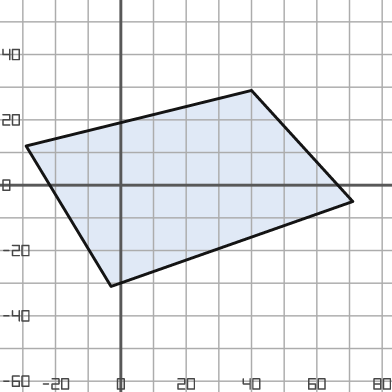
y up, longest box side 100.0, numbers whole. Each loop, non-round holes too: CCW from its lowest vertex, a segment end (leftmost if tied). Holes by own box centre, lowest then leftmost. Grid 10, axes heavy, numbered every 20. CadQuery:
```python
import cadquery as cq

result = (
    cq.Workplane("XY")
    .moveTo(-3.0, -31.0)
    .lineTo(71.0, -5.0)
    .lineTo(40.0, 29.0)
    .lineTo(-29.0, 12.0)
    .close()
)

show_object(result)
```